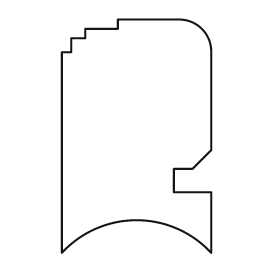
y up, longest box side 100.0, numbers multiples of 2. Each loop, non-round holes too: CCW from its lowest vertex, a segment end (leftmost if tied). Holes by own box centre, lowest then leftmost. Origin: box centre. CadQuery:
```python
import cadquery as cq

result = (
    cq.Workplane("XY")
    .moveTo(-32.0, -50.0)
    .threePointArc((0.0, -36.0), (32.0, -50.0))
    .lineTo(32.0, -24.0)
    .lineTo(16.0, -24.0)
    .lineTo(16.0, -14.0)
    .lineTo(24.0, -14.0)
    .lineTo(32.0, -6.0)
    .lineTo(32.0, 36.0)
    .threePointArc((28.0, 46.0), (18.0, 50.0))
    .lineTo(-8.0, 50.0)
    .lineTo(-8.0, 46.0)
    .lineTo(-22.0, 46.0)
    .lineTo(-22.0, 42.0)
    .lineTo(-28.0, 42.0)
    .lineTo(-28.0, 36.0)
    .lineTo(-32.0, 36.0)
    .close()
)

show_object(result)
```